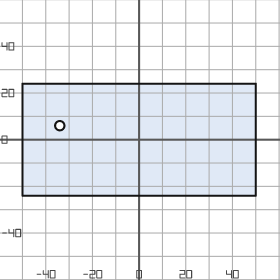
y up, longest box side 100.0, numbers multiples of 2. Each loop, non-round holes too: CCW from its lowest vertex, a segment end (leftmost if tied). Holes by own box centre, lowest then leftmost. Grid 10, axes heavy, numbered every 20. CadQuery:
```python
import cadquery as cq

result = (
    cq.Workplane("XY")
    .moveTo(-50.0, -24.0)
    .lineTo(50.0, -24.0)
    .lineTo(50.0, 24.0)
    .lineTo(-50.0, 24.0)
    .close()
    .moveTo(-34.0, 6.0)
    .circle(2.0)
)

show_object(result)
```